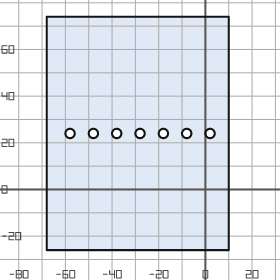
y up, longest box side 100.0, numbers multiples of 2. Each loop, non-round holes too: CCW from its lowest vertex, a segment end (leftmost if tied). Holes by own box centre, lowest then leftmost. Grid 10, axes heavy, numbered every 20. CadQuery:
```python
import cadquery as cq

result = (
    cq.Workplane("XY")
    .moveTo(-68.0, -26.0)
    .lineTo(10.0, -26.0)
    .lineTo(10.0, 74.0)
    .lineTo(-68.0, 74.0)
    .close()
    .moveTo(-58.0, 24.0)
    .circle(2.0)
    .moveTo(-48.0, 24.0)
    .circle(2.0)
    .moveTo(-38.0, 24.0)
    .circle(2.0)
    .moveTo(-28.0, 24.0)
    .circle(2.0)
    .moveTo(-18.0, 24.0)
    .circle(2.0)
    .moveTo(-8.0, 24.0)
    .circle(2.0)
    .moveTo(2.0, 24.0)
    .circle(2.0)
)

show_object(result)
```